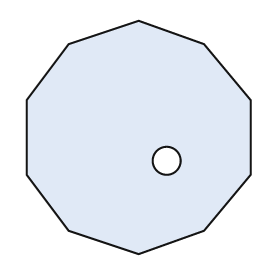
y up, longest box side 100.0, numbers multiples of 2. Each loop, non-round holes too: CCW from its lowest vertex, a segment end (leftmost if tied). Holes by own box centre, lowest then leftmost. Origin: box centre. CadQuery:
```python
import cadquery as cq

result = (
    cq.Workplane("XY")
    .moveTo(0.0, -50.0)
    .lineTo(28.0, -40.0)
    .lineTo(48.0, -16.0)
    .lineTo(48.0, 16.0)
    .lineTo(28.0, 40.0)
    .lineTo(0.0, 50.0)
    .lineTo(-30.0, 40.0)
    .lineTo(-48.0, 16.0)
    .lineTo(-48.0, -16.0)
    .lineTo(-30.0, -40.0)
    .close()
    .moveTo(12.0, -10.0)
    .circle(6.0)
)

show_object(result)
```